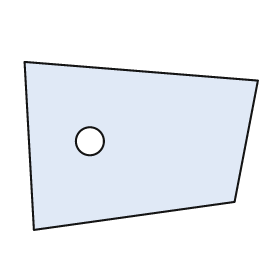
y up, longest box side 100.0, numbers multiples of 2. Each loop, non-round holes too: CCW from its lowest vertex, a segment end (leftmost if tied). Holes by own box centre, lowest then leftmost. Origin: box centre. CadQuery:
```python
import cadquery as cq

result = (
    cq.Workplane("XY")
    .moveTo(-46.0, -36.0)
    .lineTo(40.0, -24.0)
    .lineTo(50.0, 28.0)
    .lineTo(-50.0, 36.0)
    .close()
    .moveTo(-22.0, 2.0)
    .circle(6.0)
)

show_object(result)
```